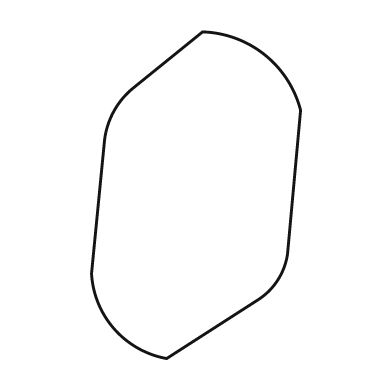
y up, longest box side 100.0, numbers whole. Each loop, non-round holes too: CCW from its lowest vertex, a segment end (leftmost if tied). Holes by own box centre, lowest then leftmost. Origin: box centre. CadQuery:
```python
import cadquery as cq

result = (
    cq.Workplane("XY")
    .moveTo(-9.0, -50.0)
    .lineTo(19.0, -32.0)
    .threePointArc((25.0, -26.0), (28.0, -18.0))
    .lineTo(32.0, 26.0)
    .threePointArc((21.0, 43.0), (2.0, 50.0))
    .lineTo(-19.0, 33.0)
    .threePointArc((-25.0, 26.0), (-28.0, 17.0))
    .lineTo(-32.0, -24.0)
    .threePointArc((-25.0, -41.0), (-9.0, -50.0))
    .close()
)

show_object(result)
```